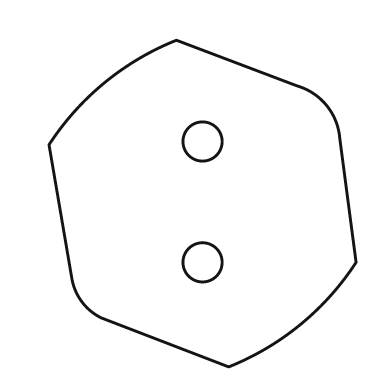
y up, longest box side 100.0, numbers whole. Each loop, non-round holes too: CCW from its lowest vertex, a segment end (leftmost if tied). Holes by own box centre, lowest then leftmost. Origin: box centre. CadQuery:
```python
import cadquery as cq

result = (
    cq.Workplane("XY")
    .moveTo(8.0, -50.0)
    .threePointArc((30.0, -37.0), (47.0, -18.0))
    .lineTo(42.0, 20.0)
    .threePointArc((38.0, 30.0), (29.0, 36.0))
    .lineTo(-8.0, 50.0)
    .threePointArc((-30.0, 37.0), (-47.0, 18.0))
    .lineTo(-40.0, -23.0)
    .threePointArc((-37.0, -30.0), (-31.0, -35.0))
    .close()
    .moveTo(0.0, -18.0)
    .circle(6.0)
    .moveTo(0.0, 19.0)
    .circle(6.0)
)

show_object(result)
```